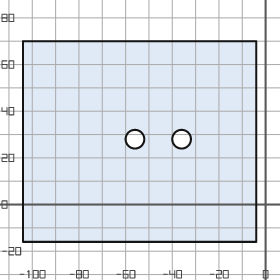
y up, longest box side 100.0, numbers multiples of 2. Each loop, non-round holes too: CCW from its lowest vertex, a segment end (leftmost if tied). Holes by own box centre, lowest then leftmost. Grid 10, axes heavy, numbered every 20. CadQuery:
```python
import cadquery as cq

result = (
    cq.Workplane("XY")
    .moveTo(-104.0, -16.0)
    .lineTo(-4.0, -16.0)
    .lineTo(-4.0, 70.0)
    .lineTo(-104.0, 70.0)
    .close()
    .moveTo(-56.0, 28.0)
    .circle(4.0)
    .moveTo(-36.0, 28.0)
    .circle(4.0)
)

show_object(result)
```